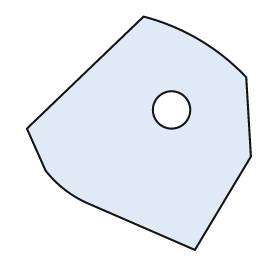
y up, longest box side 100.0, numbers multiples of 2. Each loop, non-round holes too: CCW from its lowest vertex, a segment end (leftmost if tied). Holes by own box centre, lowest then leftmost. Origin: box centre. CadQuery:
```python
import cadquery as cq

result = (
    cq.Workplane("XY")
    .moveTo(24.0, -50.0)
    .lineTo(48.0, -10.0)
    .lineTo(46.0, 24.0)
    .threePointArc((26.0, 40.0), (2.0, 50.0))
    .lineTo(-48.0, 2.0)
    .lineTo(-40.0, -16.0)
    .threePointArc((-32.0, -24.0), (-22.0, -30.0))
    .close()
    .moveTo(14.0, 10.0)
    .circle(8.0)
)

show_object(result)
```